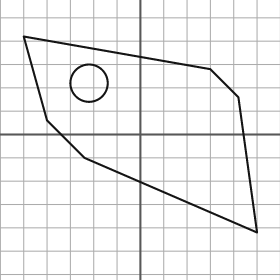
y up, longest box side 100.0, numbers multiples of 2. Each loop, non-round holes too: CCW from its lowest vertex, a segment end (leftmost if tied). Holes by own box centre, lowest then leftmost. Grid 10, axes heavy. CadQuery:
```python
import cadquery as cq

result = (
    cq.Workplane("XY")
    .moveTo(50.0, -42.0)
    .lineTo(42.0, 16.0)
    .lineTo(30.0, 28.0)
    .lineTo(-50.0, 42.0)
    .lineTo(-40.0, 6.0)
    .lineTo(-24.0, -10.0)
    .close()
    .moveTo(-22.0, 22.0)
    .circle(8.0)
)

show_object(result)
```